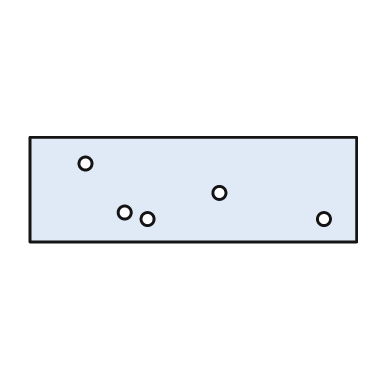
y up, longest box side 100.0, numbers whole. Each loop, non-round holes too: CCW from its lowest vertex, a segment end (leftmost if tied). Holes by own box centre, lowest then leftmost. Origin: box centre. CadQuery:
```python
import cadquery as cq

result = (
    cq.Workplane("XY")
    .moveTo(-50.0, -16.0)
    .lineTo(50.0, -16.0)
    .lineTo(50.0, 16.0)
    .lineTo(-50.0, 16.0)
    .close()
    .moveTo(-14.0, -9.0)
    .circle(2.0)
    .moveTo(40.0, -9.0)
    .circle(2.0)
    .moveTo(-21.0, -7.0)
    .circle(2.0)
    .moveTo(8.0, -1.0)
    .circle(2.0)
    .moveTo(-33.0, 8.0)
    .circle(2.0)
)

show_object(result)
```